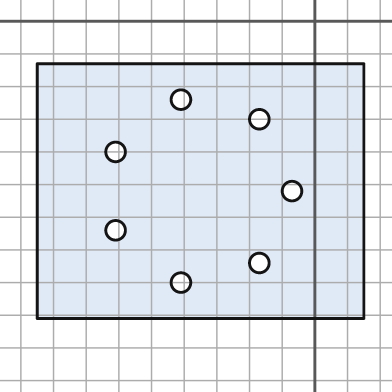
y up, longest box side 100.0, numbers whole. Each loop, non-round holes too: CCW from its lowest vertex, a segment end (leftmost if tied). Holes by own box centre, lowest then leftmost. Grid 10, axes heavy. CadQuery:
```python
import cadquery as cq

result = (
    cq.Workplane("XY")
    .moveTo(-85.0, -91.0)
    .lineTo(15.0, -91.0)
    .lineTo(15.0, -13.0)
    .lineTo(-85.0, -13.0)
    .close()
    .moveTo(-41.0, -80.0)
    .circle(3.0)
    .moveTo(-17.0, -74.0)
    .circle(3.0)
    .moveTo(-61.0, -64.0)
    .circle(3.0)
    .moveTo(-7.0, -52.0)
    .circle(3.0)
    .moveTo(-61.0, -40.0)
    .circle(3.0)
    .moveTo(-17.0, -30.0)
    .circle(3.0)
    .moveTo(-41.0, -24.0)
    .circle(3.0)
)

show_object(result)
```